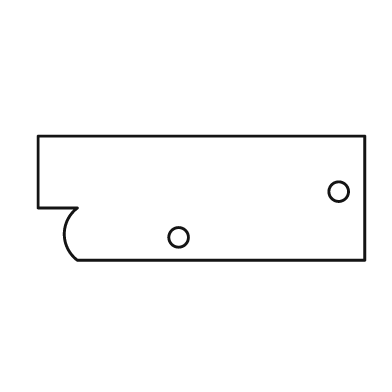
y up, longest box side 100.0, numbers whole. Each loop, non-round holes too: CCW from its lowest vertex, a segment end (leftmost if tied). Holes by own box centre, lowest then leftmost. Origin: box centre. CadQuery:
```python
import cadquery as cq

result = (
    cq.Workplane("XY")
    .moveTo(-38.0, -19.0)
    .lineTo(50.0, -19.0)
    .lineTo(50.0, 19.0)
    .lineTo(-50.0, 19.0)
    .lineTo(-50.0, -3.0)
    .lineTo(-38.0, -3.0)
    .threePointArc((-42.0, -11.0), (-38.0, -19.0))
    .close()
    .moveTo(-7.0, -12.0)
    .circle(3.0)
    .moveTo(42.0, 2.0)
    .circle(3.0)
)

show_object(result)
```